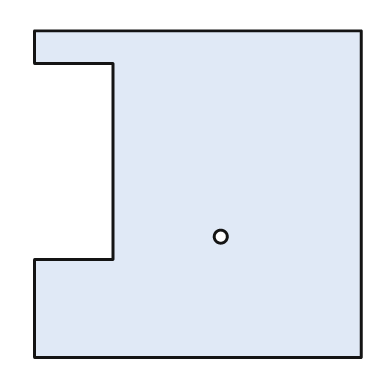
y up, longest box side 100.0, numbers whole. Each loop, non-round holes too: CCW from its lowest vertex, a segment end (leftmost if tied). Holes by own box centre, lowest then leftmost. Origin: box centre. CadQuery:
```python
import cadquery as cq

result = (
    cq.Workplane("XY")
    .moveTo(-50.0, -50.0)
    .lineTo(50.0, -50.0)
    .lineTo(50.0, 50.0)
    .lineTo(-50.0, 50.0)
    .lineTo(-50.0, 40.0)
    .lineTo(-26.0, 40.0)
    .lineTo(-26.0, -20.0)
    .lineTo(-50.0, -20.0)
    .close()
    .moveTo(7.0, -13.0)
    .circle(2.0)
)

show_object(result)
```